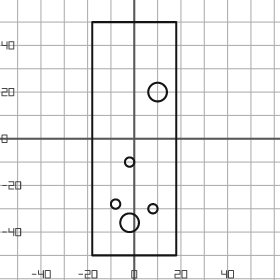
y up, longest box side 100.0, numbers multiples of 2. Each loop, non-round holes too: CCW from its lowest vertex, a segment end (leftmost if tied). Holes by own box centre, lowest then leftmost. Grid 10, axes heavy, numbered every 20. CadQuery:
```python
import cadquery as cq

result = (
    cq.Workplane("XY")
    .moveTo(-18.0, -50.0)
    .lineTo(18.0, -50.0)
    .lineTo(18.0, 50.0)
    .lineTo(-18.0, 50.0)
    .close()
    .moveTo(-2.0, -36.0)
    .circle(4.0)
    .moveTo(8.0, -30.0)
    .circle(2.0)
    .moveTo(-8.0, -28.0)
    .circle(2.0)
    .moveTo(-2.0, -10.0)
    .circle(2.0)
    .moveTo(10.0, 20.0)
    .circle(4.0)
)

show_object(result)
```